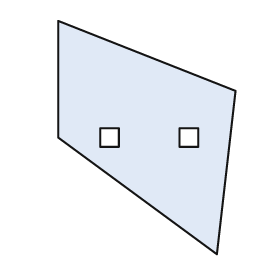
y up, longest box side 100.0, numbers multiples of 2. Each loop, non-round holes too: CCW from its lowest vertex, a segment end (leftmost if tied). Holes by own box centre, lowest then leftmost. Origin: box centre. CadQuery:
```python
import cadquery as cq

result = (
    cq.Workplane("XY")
    .moveTo(30.0, -50.0)
    .lineTo(38.0, 20.0)
    .lineTo(-38.0, 50.0)
    .lineTo(-38.0, 0.0)
    .close()
    .moveTo(-20.0, -4.0)
    .lineTo(-12.0, -4.0)
    .lineTo(-12.0, 4.0)
    .lineTo(-20.0, 4.0)
    .close()
    .moveTo(14.0, -4.0)
    .lineTo(22.0, -4.0)
    .lineTo(22.0, 4.0)
    .lineTo(14.0, 4.0)
    .close()
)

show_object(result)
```